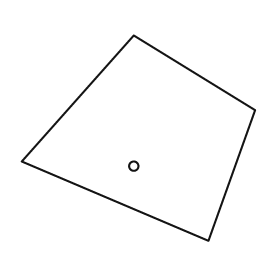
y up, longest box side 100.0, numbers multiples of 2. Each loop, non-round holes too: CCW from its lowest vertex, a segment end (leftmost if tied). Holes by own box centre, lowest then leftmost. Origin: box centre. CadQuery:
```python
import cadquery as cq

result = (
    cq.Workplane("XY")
    .moveTo(30.0, -44.0)
    .lineTo(50.0, 12.0)
    .lineTo(-2.0, 44.0)
    .lineTo(-50.0, -10.0)
    .close()
    .moveTo(-2.0, -12.0)
    .circle(2.0)
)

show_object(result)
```